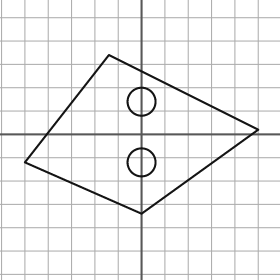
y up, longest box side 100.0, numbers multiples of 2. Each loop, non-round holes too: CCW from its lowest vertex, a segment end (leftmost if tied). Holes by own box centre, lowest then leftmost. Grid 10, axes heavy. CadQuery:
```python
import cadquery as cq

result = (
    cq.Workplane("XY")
    .moveTo(0.0, -34.0)
    .lineTo(50.0, 2.0)
    .lineTo(-14.0, 34.0)
    .lineTo(-50.0, -12.0)
    .close()
    .moveTo(0.0, -12.0)
    .circle(6.0)
    .moveTo(0.0, 14.0)
    .circle(6.0)
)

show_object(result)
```